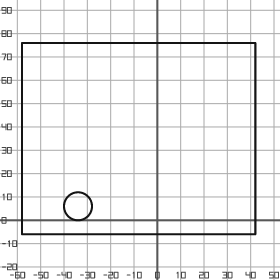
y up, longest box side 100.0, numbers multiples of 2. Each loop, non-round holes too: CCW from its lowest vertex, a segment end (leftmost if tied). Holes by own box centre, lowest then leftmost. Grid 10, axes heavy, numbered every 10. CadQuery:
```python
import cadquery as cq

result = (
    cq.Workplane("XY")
    .moveTo(-58.0, -6.0)
    .lineTo(42.0, -6.0)
    .lineTo(42.0, 76.0)
    .lineTo(-58.0, 76.0)
    .close()
    .moveTo(-34.0, 6.0)
    .circle(6.0)
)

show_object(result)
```